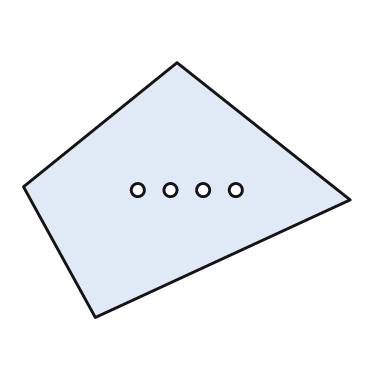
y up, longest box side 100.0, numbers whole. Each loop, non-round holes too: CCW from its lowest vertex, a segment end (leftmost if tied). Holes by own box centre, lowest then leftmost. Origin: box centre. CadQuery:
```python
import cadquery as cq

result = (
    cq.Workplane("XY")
    .moveTo(-28.0, -39.0)
    .lineTo(50.0, -3.0)
    .lineTo(-3.0, 39.0)
    .lineTo(-50.0, 1.0)
    .close()
    .moveTo(-15.0, 0.0)
    .circle(2.0)
    .moveTo(-5.0, 0.0)
    .circle(2.0)
    .moveTo(5.0, 0.0)
    .circle(2.0)
    .moveTo(15.0, 0.0)
    .circle(2.0)
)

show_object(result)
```